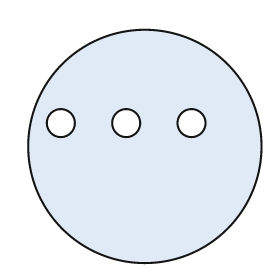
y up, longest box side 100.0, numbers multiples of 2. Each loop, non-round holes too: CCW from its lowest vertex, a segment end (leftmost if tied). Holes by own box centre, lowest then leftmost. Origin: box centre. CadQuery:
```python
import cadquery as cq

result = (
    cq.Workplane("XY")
    .moveTo(0.0, 0.0)
    .circle(50.0)
    .moveTo(-36.0, 10.0)
    .circle(6.0)
    .moveTo(-8.0, 10.0)
    .circle(6.0)
    .moveTo(20.0, 10.0)
    .circle(6.0)
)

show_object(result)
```